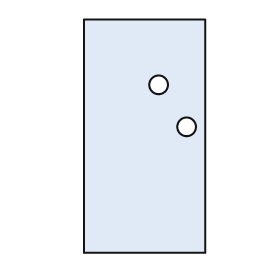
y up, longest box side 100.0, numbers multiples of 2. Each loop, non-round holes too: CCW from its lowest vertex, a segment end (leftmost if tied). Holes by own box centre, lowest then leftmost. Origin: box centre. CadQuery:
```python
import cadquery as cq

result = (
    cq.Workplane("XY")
    .moveTo(-26.0, -50.0)
    .lineTo(26.0, -50.0)
    .lineTo(26.0, 50.0)
    .lineTo(-26.0, 50.0)
    .close()
    .moveTo(18.0, 4.0)
    .circle(4.0)
    .moveTo(6.0, 22.0)
    .circle(4.0)
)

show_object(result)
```